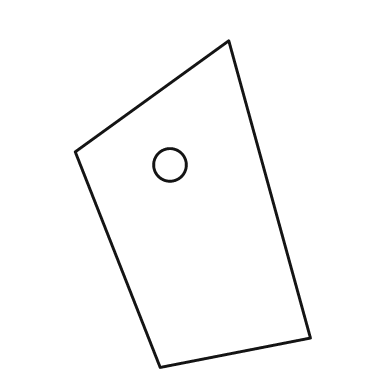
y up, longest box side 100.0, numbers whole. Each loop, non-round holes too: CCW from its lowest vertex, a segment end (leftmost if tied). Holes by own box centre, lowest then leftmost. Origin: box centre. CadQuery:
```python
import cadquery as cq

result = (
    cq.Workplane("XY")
    .moveTo(-10.0, -50.0)
    .lineTo(36.0, -41.0)
    .lineTo(11.0, 50.0)
    .lineTo(-36.0, 16.0)
    .close()
    .moveTo(-7.0, 12.0)
    .circle(5.0)
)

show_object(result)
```